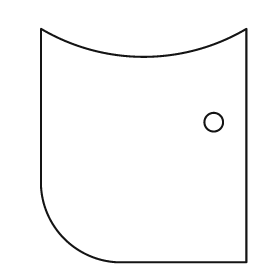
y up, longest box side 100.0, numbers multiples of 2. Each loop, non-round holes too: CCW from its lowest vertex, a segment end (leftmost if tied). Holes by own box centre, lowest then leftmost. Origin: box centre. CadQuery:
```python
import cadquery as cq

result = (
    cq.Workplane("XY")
    .moveTo(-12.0, -50.0)
    .lineTo(44.0, -50.0)
    .lineTo(44.0, 50.0)
    .threePointArc((0.0, 38.0), (-44.0, 50.0))
    .lineTo(-44.0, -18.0)
    .threePointArc((-34.0, -40.0), (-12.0, -50.0))
    .close()
    .moveTo(30.0, 10.0)
    .circle(4.0)
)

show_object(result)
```